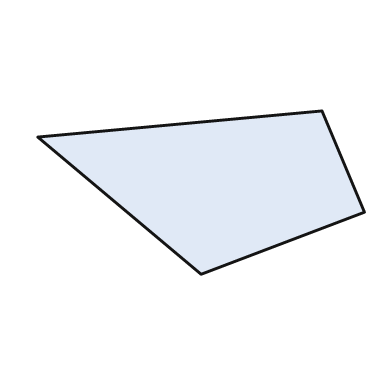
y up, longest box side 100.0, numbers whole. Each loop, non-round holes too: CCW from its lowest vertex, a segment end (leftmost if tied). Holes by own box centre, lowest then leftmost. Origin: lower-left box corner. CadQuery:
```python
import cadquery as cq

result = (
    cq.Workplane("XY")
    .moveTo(50.0, 0.0)
    .lineTo(100.0, 19.0)
    .lineTo(87.0, 50.0)
    .lineTo(0.0, 42.0)
    .close()
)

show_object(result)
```